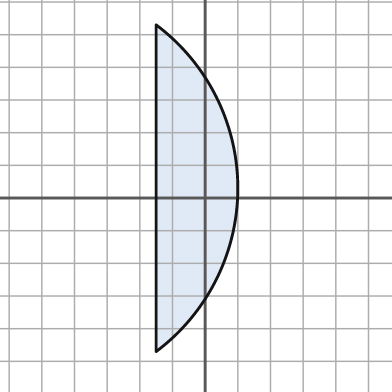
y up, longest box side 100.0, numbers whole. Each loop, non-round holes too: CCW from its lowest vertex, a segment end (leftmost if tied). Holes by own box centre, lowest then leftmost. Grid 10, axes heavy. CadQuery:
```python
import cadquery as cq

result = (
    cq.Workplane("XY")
    .moveTo(-15.0, -47.0)
    .threePointArc((10.0, 3.0), (-15.0, 53.0))
    .close()
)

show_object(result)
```